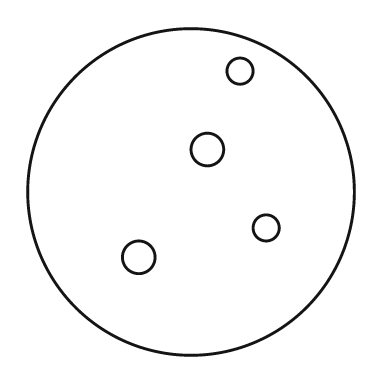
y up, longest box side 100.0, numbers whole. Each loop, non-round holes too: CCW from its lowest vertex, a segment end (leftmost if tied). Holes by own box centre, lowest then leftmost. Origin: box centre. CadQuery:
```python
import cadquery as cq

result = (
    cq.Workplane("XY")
    .moveTo(0.0, 0.0)
    .circle(50.0)
    .moveTo(-16.0, -20.0)
    .circle(5.0)
    .moveTo(23.0, -11.0)
    .circle(4.0)
    .moveTo(5.0, 13.0)
    .circle(5.0)
    .moveTo(15.0, 37.0)
    .circle(4.0)
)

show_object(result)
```